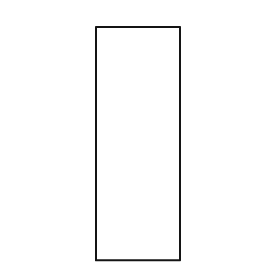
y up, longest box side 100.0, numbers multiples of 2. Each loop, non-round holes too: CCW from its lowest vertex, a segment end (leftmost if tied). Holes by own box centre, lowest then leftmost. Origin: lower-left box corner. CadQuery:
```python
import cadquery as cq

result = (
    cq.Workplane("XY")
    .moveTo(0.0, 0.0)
    .lineTo(36.0, 0.0)
    .lineTo(36.0, 100.0)
    .lineTo(0.0, 100.0)
    .close()
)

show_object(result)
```